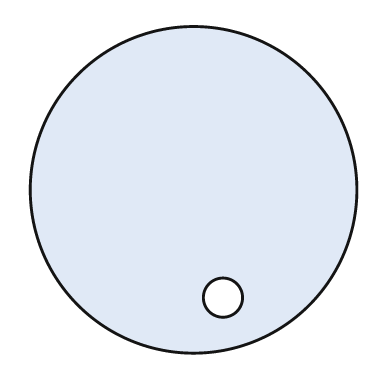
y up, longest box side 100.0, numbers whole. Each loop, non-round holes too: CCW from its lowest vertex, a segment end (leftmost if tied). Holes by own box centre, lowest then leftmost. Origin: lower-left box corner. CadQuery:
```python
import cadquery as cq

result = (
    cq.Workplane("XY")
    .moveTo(50.0, 50.0)
    .circle(50.0)
    .moveTo(59.0, 17.0)
    .circle(6.0)
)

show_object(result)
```